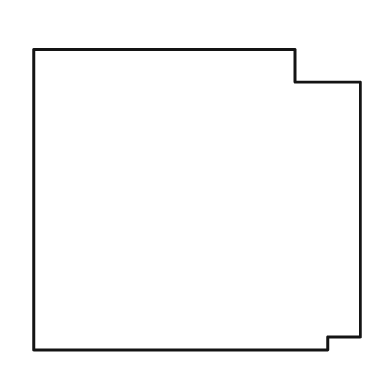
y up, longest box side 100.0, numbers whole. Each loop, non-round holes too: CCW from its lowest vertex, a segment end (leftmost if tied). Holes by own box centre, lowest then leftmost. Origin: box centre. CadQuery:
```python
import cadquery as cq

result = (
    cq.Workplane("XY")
    .moveTo(-50.0, -46.0)
    .lineTo(40.0, -46.0)
    .lineTo(40.0, -42.0)
    .lineTo(50.0, -42.0)
    .lineTo(50.0, 36.0)
    .lineTo(30.0, 36.0)
    .lineTo(30.0, 46.0)
    .lineTo(-50.0, 46.0)
    .close()
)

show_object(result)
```